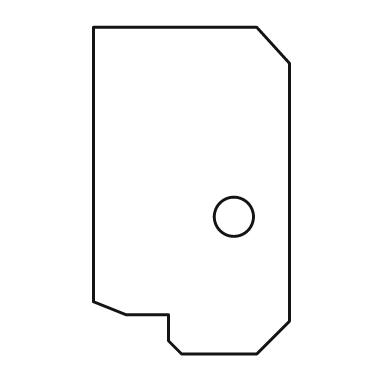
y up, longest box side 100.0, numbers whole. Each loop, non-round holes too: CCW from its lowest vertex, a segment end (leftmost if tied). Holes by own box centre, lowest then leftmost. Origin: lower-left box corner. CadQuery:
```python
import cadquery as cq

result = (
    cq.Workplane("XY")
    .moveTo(27.0, 0.0)
    .lineTo(50.0, 0.0)
    .lineTo(60.0, 10.0)
    .lineTo(60.0, 89.0)
    .lineTo(50.0, 100.0)
    .lineTo(0.0, 100.0)
    .lineTo(0.0, 16.0)
    .lineTo(10.0, 12.0)
    .lineTo(23.0, 12.0)
    .lineTo(23.0, 4.0)
    .close()
    .moveTo(43.0, 42.0)
    .circle(6.0)
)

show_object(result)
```